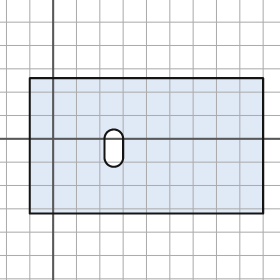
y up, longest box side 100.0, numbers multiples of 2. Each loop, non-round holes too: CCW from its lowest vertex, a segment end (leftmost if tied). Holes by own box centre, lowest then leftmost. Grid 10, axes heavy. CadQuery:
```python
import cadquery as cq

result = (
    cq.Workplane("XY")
    .moveTo(-10.0, -32.0)
    .lineTo(90.0, -32.0)
    .lineTo(90.0, 26.0)
    .lineTo(-10.0, 26.0)
    .close()
    .moveTo(22.0, -8.0)
    .threePointArc((26.0, -12.0), (30.0, -8.0))
    .lineTo(30.0, 0.0)
    .threePointArc((26.0, 4.0), (22.0, 0.0))
    .close()
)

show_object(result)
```